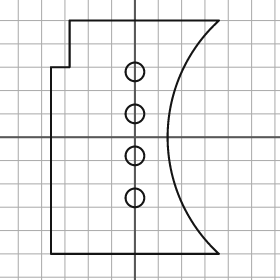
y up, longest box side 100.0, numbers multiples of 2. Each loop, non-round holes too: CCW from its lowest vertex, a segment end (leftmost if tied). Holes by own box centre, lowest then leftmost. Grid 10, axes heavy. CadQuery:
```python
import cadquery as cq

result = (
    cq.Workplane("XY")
    .moveTo(-36.0, -50.0)
    .lineTo(36.0, -50.0)
    .threePointArc((14.0, 0.0), (36.0, 50.0))
    .lineTo(-28.0, 50.0)
    .lineTo(-28.0, 30.0)
    .lineTo(-36.0, 30.0)
    .close()
    .moveTo(0.0, -26.0)
    .circle(4.0)
    .moveTo(0.0, -8.0)
    .circle(4.0)
    .moveTo(0.0, 10.0)
    .circle(4.0)
    .moveTo(0.0, 28.0)
    .circle(4.0)
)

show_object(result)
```